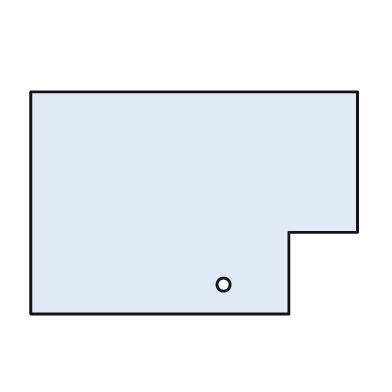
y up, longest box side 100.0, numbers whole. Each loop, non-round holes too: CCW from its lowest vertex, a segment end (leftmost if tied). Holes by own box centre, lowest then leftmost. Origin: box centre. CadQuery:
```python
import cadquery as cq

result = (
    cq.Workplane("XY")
    .moveTo(-50.0, -34.0)
    .lineTo(29.0, -34.0)
    .lineTo(29.0, -9.0)
    .lineTo(50.0, -9.0)
    .lineTo(50.0, 34.0)
    .lineTo(-50.0, 34.0)
    .close()
    .moveTo(9.0, -25.0)
    .circle(2.0)
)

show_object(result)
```